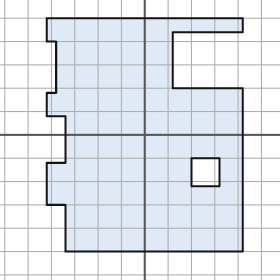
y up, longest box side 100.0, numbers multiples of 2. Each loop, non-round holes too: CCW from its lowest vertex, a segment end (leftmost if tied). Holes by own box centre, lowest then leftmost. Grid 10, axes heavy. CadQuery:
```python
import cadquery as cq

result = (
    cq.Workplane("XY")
    .moveTo(-34.0, -50.0)
    .lineTo(42.0, -50.0)
    .lineTo(42.0, 20.0)
    .lineTo(12.0, 20.0)
    .lineTo(12.0, 44.0)
    .lineTo(42.0, 44.0)
    .lineTo(42.0, 50.0)
    .lineTo(-42.0, 50.0)
    .lineTo(-42.0, 40.0)
    .lineTo(-38.0, 40.0)
    .lineTo(-38.0, 18.0)
    .lineTo(-42.0, 18.0)
    .lineTo(-42.0, 8.0)
    .lineTo(-34.0, 8.0)
    .lineTo(-34.0, -12.0)
    .lineTo(-42.0, -12.0)
    .lineTo(-42.0, -30.0)
    .lineTo(-34.0, -30.0)
    .close()
    .moveTo(20.0, -22.0)
    .lineTo(32.0, -22.0)
    .lineTo(32.0, -10.0)
    .lineTo(20.0, -10.0)
    .close()
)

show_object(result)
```